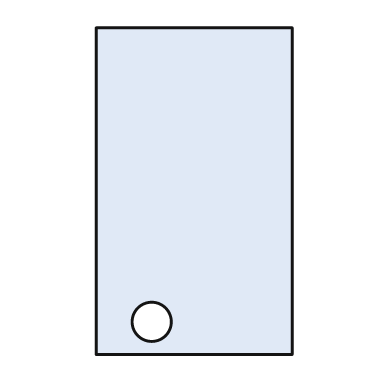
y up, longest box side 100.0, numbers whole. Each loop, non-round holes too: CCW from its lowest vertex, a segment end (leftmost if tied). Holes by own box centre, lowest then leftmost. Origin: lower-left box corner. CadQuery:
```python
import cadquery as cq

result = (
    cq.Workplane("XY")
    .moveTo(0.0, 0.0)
    .lineTo(60.0, 0.0)
    .lineTo(60.0, 100.0)
    .lineTo(0.0, 100.0)
    .close()
    .moveTo(17.0, 10.0)
    .circle(6.0)
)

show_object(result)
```